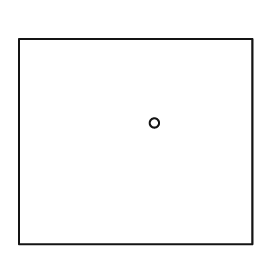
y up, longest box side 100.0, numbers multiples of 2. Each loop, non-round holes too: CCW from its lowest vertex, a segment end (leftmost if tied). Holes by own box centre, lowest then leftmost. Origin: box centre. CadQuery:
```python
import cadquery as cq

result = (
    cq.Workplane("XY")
    .moveTo(-50.0, -44.0)
    .lineTo(50.0, -44.0)
    .lineTo(50.0, 44.0)
    .lineTo(-50.0, 44.0)
    .close()
    .moveTo(8.0, 8.0)
    .circle(2.0)
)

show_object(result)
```